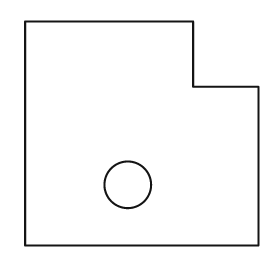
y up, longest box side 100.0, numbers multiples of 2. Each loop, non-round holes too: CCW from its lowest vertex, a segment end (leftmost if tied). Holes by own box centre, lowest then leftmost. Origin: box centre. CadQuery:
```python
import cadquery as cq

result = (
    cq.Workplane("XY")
    .moveTo(-50.0, -48.0)
    .lineTo(50.0, -48.0)
    .lineTo(50.0, 20.0)
    .lineTo(22.0, 20.0)
    .lineTo(22.0, 48.0)
    .lineTo(-50.0, 48.0)
    .close()
    .moveTo(-6.0, -22.0)
    .circle(10.0)
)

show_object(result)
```